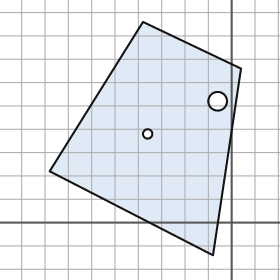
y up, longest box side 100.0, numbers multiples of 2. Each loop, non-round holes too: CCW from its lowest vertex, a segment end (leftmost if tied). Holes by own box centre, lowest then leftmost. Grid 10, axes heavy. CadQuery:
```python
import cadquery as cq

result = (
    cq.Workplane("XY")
    .moveTo(-8.0, -14.0)
    .lineTo(4.0, 66.0)
    .lineTo(-38.0, 86.0)
    .lineTo(-78.0, 22.0)
    .close()
    .moveTo(-36.0, 38.0)
    .circle(2.0)
    .moveTo(-6.0, 52.0)
    .circle(4.0)
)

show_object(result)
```